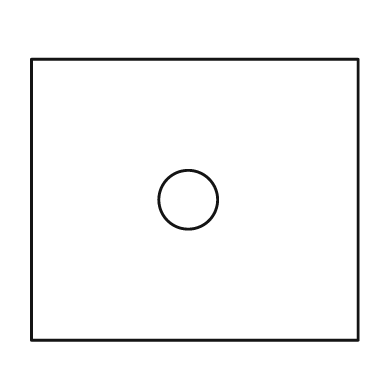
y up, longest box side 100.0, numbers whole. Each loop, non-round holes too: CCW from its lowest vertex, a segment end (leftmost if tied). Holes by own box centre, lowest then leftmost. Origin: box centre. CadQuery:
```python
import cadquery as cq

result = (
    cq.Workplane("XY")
    .moveTo(-50.0, -43.0)
    .lineTo(50.0, -43.0)
    .lineTo(50.0, 43.0)
    .lineTo(-50.0, 43.0)
    .close()
    .moveTo(-2.0, 0.0)
    .circle(9.0)
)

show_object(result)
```